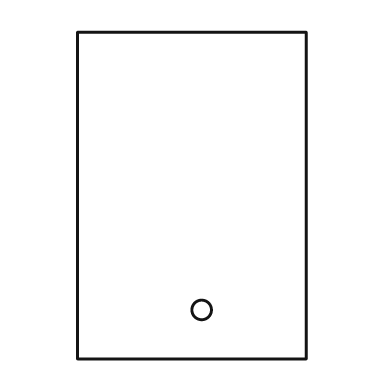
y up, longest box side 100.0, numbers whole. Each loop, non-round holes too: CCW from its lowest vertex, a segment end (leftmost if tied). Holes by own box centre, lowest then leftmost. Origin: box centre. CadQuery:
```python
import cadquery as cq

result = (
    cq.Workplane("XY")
    .moveTo(-35.0, -50.0)
    .lineTo(35.0, -50.0)
    .lineTo(35.0, 50.0)
    .lineTo(-35.0, 50.0)
    .close()
    .moveTo(3.0, -35.0)
    .circle(3.0)
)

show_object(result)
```